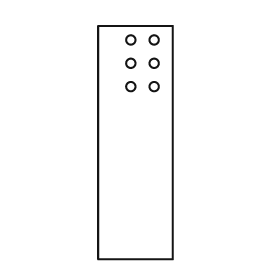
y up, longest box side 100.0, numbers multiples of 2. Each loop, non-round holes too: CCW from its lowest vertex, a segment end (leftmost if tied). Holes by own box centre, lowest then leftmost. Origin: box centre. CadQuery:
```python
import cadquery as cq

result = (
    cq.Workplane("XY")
    .moveTo(-16.0, -50.0)
    .lineTo(16.0, -50.0)
    .lineTo(16.0, 50.0)
    .lineTo(-16.0, 50.0)
    .close()
    .moveTo(-2.0, 24.0)
    .circle(2.0)
    .moveTo(8.0, 24.0)
    .circle(2.0)
    .moveTo(-2.0, 34.0)
    .circle(2.0)
    .moveTo(8.0, 34.0)
    .circle(2.0)
    .moveTo(-2.0, 44.0)
    .circle(2.0)
    .moveTo(8.0, 44.0)
    .circle(2.0)
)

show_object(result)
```